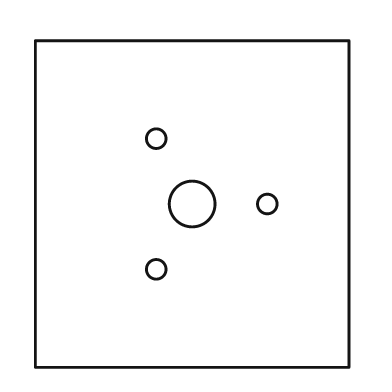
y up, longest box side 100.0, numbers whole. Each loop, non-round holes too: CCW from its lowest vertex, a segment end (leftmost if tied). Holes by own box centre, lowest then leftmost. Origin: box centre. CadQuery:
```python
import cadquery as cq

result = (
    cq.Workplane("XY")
    .moveTo(-48.0, -50.0)
    .lineTo(48.0, -50.0)
    .lineTo(48.0, 50.0)
    .lineTo(-48.0, 50.0)
    .close()
    .moveTo(-11.0, -20.0)
    .circle(3.0)
    .moveTo(0.0, 0.0)
    .circle(7.0)
    .moveTo(23.0, 0.0)
    .circle(3.0)
    .moveTo(-11.0, 20.0)
    .circle(3.0)
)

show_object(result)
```